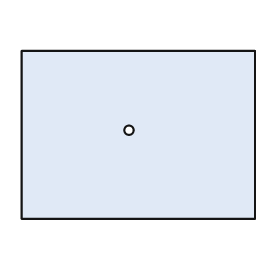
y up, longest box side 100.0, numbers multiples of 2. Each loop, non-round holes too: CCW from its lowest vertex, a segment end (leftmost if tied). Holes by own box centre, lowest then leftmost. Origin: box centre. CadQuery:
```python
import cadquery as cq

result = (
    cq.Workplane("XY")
    .moveTo(-50.0, -36.0)
    .lineTo(50.0, -36.0)
    .lineTo(50.0, 36.0)
    .lineTo(-50.0, 36.0)
    .close()
    .moveTo(-4.0, 2.0)
    .circle(2.0)
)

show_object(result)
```